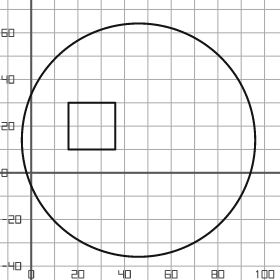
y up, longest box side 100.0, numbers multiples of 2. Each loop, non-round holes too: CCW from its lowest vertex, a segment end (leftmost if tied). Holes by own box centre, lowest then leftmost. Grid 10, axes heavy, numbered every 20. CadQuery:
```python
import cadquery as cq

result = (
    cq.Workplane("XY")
    .moveTo(46.0, 14.0)
    .circle(50.0)
    .moveTo(16.0, 10.0)
    .lineTo(36.0, 10.0)
    .lineTo(36.0, 30.0)
    .lineTo(16.0, 30.0)
    .close()
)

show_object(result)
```